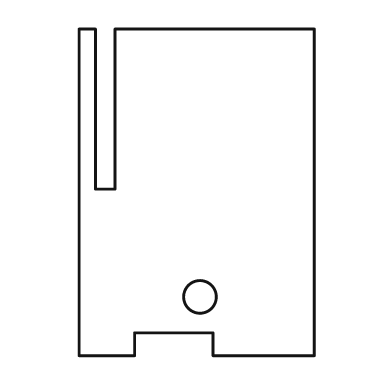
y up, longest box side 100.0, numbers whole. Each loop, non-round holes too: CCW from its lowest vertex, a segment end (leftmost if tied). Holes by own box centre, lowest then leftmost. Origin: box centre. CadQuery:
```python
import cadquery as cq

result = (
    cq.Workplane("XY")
    .moveTo(-36.0, -50.0)
    .lineTo(-19.0, -50.0)
    .lineTo(-19.0, -43.0)
    .lineTo(5.0, -43.0)
    .lineTo(5.0, -50.0)
    .lineTo(36.0, -50.0)
    .lineTo(36.0, 50.0)
    .lineTo(-25.0, 50.0)
    .lineTo(-25.0, 1.0)
    .lineTo(-31.0, 1.0)
    .lineTo(-31.0, 50.0)
    .lineTo(-36.0, 50.0)
    .close()
    .moveTo(1.0, -32.0)
    .circle(5.0)
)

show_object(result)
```